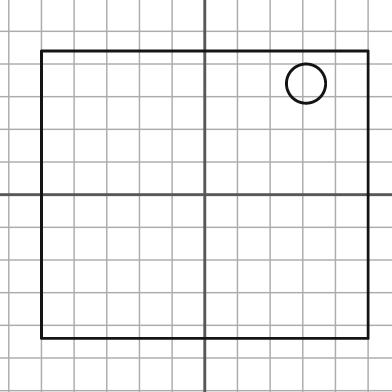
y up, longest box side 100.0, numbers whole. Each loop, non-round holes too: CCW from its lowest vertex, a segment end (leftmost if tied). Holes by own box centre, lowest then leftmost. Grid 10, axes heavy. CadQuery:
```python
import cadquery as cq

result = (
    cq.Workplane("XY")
    .moveTo(-50.0, -44.0)
    .lineTo(50.0, -44.0)
    .lineTo(50.0, 44.0)
    .lineTo(-50.0, 44.0)
    .close()
    .moveTo(31.0, 34.0)
    .circle(6.0)
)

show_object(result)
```